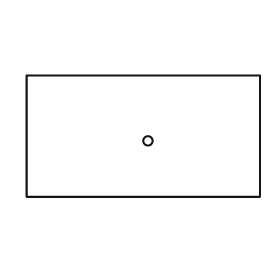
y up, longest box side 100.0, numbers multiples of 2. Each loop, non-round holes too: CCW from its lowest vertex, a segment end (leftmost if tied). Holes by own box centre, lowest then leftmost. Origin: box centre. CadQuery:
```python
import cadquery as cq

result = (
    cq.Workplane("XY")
    .moveTo(-50.0, -26.0)
    .lineTo(50.0, -26.0)
    .lineTo(50.0, 26.0)
    .lineTo(-50.0, 26.0)
    .close()
    .moveTo(2.0, -2.0)
    .circle(2.0)
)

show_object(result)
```